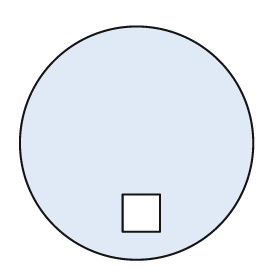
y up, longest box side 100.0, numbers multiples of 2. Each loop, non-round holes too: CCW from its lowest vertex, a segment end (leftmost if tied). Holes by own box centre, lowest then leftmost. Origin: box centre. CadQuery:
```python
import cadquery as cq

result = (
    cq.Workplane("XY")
    .moveTo(0.0, 0.0)
    .circle(50.0)
    .moveTo(-6.0, -38.0)
    .lineTo(10.0, -38.0)
    .lineTo(10.0, -22.0)
    .lineTo(-6.0, -22.0)
    .close()
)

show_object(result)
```